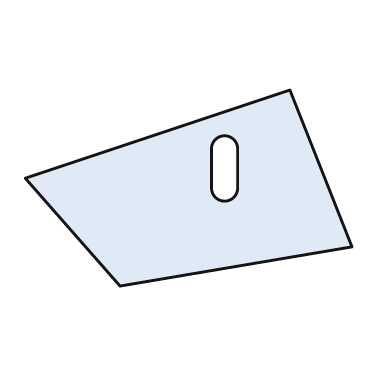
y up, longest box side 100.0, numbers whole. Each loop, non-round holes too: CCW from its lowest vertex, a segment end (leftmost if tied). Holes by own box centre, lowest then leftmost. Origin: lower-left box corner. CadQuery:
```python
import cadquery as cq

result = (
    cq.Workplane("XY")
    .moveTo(29.0, 0.0)
    .lineTo(100.0, 12.0)
    .lineTo(81.0, 60.0)
    .lineTo(0.0, 33.0)
    .close()
    .moveTo(57.0, 30.0)
    .threePointArc((61.0, 26.0), (65.0, 30.0))
    .lineTo(65.0, 42.0)
    .threePointArc((61.0, 46.0), (57.0, 42.0))
    .close()
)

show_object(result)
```